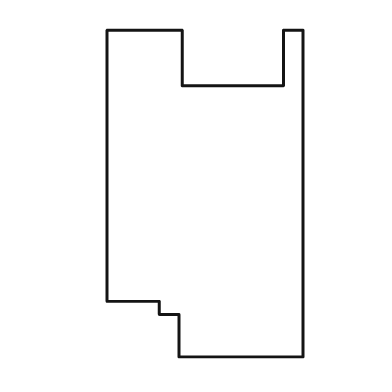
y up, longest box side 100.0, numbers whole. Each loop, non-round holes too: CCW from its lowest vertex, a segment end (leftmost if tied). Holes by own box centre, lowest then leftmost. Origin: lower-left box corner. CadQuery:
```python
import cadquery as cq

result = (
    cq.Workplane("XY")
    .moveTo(22.0, 0.0)
    .lineTo(60.0, 0.0)
    .lineTo(60.0, 100.0)
    .lineTo(54.0, 100.0)
    .lineTo(54.0, 83.0)
    .lineTo(23.0, 83.0)
    .lineTo(23.0, 100.0)
    .lineTo(0.0, 100.0)
    .lineTo(0.0, 17.0)
    .lineTo(16.0, 17.0)
    .lineTo(16.0, 13.0)
    .lineTo(22.0, 13.0)
    .close()
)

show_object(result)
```